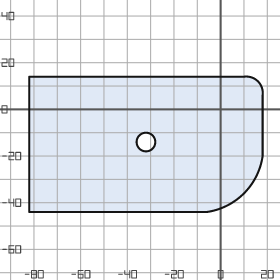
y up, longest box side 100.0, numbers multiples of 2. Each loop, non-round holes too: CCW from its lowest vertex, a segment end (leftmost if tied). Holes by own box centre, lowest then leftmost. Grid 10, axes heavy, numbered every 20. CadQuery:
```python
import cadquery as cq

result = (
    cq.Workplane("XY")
    .moveTo(-82.0, -44.0)
    .lineTo(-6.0, -44.0)
    .threePointArc((10.0, -36.0), (18.0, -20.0))
    .lineTo(18.0, 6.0)
    .threePointArc((16.0, 12.0), (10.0, 14.0))
    .lineTo(-82.0, 14.0)
    .close()
    .moveTo(-32.0, -14.0)
    .circle(4.0)
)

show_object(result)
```